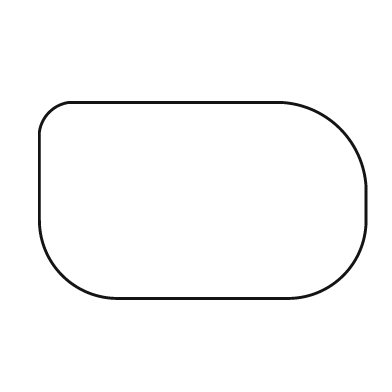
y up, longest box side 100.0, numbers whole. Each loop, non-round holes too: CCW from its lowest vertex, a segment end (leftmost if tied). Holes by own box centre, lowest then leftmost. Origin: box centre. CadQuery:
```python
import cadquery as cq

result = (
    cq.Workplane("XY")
    .moveTo(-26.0, -30.0)
    .lineTo(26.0, -30.0)
    .threePointArc((43.0, -23.0), (50.0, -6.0))
    .lineTo(50.0, 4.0)
    .threePointArc((42.0, 22.0), (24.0, 30.0))
    .lineTo(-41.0, 30.0)
    .threePointArc((-47.0, 27.0), (-50.0, 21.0))
    .lineTo(-50.0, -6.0)
    .threePointArc((-43.0, -23.0), (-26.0, -30.0))
    .close()
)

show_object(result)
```